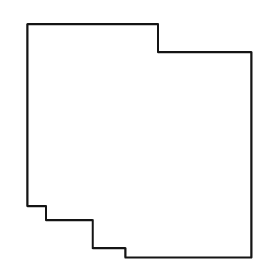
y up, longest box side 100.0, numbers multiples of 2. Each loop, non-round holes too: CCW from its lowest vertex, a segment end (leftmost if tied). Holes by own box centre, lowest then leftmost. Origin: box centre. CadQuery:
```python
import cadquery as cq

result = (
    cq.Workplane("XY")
    .moveTo(-6.0, -50.0)
    .lineTo(48.0, -50.0)
    .lineTo(48.0, 38.0)
    .lineTo(8.0, 38.0)
    .lineTo(8.0, 50.0)
    .lineTo(-48.0, 50.0)
    .lineTo(-48.0, -28.0)
    .lineTo(-40.0, -28.0)
    .lineTo(-40.0, -34.0)
    .lineTo(-20.0, -34.0)
    .lineTo(-20.0, -46.0)
    .lineTo(-6.0, -46.0)
    .close()
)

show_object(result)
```